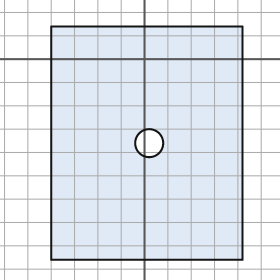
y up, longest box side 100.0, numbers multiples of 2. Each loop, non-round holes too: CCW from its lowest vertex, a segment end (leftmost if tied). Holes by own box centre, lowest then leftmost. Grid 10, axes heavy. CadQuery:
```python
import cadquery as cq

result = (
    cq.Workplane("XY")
    .moveTo(-40.0, -86.0)
    .lineTo(42.0, -86.0)
    .lineTo(42.0, 14.0)
    .lineTo(-40.0, 14.0)
    .close()
    .moveTo(2.0, -36.0)
    .circle(6.0)
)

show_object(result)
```